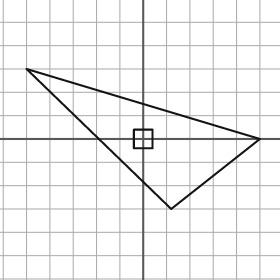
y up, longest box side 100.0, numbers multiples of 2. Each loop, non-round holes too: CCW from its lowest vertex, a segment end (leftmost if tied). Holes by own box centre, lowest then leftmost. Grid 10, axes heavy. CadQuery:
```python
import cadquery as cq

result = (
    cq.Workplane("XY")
    .moveTo(12.0, -30.0)
    .lineTo(50.0, 0.0)
    .lineTo(-50.0, 30.0)
    .close()
    .moveTo(-4.0, -4.0)
    .lineTo(4.0, -4.0)
    .lineTo(4.0, 4.0)
    .lineTo(-4.0, 4.0)
    .close()
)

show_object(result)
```